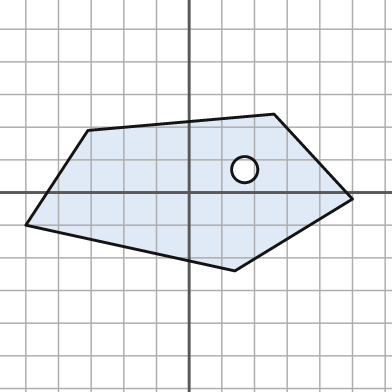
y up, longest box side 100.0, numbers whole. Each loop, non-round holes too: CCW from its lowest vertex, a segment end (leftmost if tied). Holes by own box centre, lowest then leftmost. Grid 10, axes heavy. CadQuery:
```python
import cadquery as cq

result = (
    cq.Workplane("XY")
    .moveTo(14.0, -24.0)
    .lineTo(50.0, -2.0)
    .lineTo(26.0, 24.0)
    .lineTo(-31.0, 19.0)
    .lineTo(-50.0, -10.0)
    .close()
    .moveTo(17.0, 7.0)
    .circle(4.0)
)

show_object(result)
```